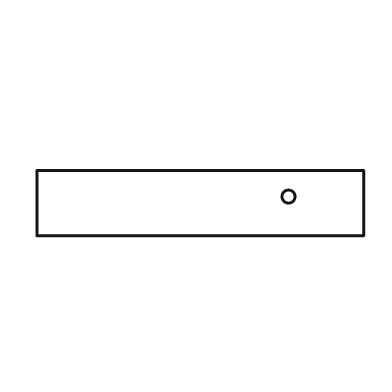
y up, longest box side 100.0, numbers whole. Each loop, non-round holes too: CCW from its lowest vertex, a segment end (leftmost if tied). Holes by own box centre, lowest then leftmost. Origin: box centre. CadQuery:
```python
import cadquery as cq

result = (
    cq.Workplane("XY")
    .moveTo(-50.0, -10.0)
    .lineTo(50.0, -10.0)
    .lineTo(50.0, 10.0)
    .lineTo(-50.0, 10.0)
    .close()
    .moveTo(27.0, 2.0)
    .circle(2.0)
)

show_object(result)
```